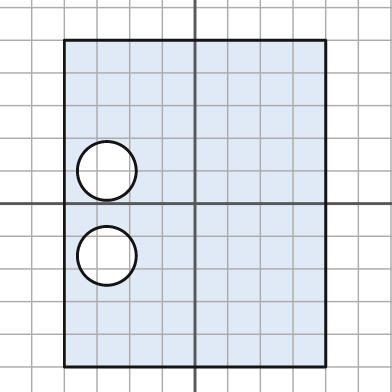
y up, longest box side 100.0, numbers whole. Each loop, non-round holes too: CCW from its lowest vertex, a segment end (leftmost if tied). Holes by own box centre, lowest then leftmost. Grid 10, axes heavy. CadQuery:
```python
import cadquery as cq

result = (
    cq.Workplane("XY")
    .moveTo(-40.0, -50.0)
    .lineTo(40.0, -50.0)
    .lineTo(40.0, 50.0)
    .lineTo(-40.0, 50.0)
    .close()
    .moveTo(-27.0, -16.0)
    .circle(9.0)
    .moveTo(-27.0, 10.0)
    .circle(9.0)
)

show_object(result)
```